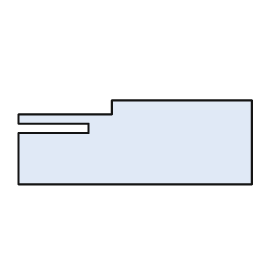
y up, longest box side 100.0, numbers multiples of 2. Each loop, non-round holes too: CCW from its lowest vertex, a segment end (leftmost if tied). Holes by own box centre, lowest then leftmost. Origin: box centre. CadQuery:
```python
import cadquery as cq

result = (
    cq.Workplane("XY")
    .moveTo(-50.0, -18.0)
    .lineTo(50.0, -18.0)
    .lineTo(50.0, 18.0)
    .lineTo(-10.0, 18.0)
    .lineTo(-10.0, 12.0)
    .lineTo(-50.0, 12.0)
    .lineTo(-50.0, 8.0)
    .lineTo(-20.0, 8.0)
    .lineTo(-20.0, 4.0)
    .lineTo(-50.0, 4.0)
    .close()
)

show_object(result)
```